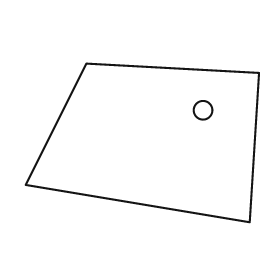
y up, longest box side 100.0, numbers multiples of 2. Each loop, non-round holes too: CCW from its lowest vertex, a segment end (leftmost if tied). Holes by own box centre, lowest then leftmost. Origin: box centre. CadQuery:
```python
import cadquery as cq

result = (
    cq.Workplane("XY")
    .moveTo(46.0, -34.0)
    .lineTo(50.0, 30.0)
    .lineTo(-24.0, 34.0)
    .lineTo(-50.0, -18.0)
    .close()
    .moveTo(26.0, 14.0)
    .circle(4.0)
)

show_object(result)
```